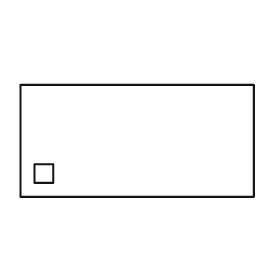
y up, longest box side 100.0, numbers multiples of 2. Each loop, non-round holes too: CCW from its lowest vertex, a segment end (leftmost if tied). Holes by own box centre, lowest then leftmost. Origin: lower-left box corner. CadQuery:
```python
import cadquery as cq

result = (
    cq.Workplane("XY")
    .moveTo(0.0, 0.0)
    .lineTo(100.0, 0.0)
    .lineTo(100.0, 48.0)
    .lineTo(0.0, 48.0)
    .close()
    .moveTo(6.0, 6.0)
    .lineTo(14.0, 6.0)
    .lineTo(14.0, 14.0)
    .lineTo(6.0, 14.0)
    .close()
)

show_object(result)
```